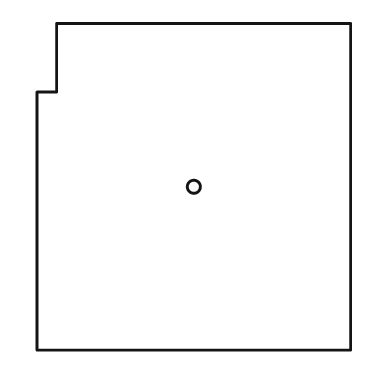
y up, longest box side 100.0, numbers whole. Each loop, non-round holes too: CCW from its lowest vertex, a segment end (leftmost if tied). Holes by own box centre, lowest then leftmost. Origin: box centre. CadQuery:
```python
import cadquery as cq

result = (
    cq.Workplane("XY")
    .moveTo(-48.0, -50.0)
    .lineTo(48.0, -50.0)
    .lineTo(48.0, 50.0)
    .lineTo(-42.0, 50.0)
    .lineTo(-42.0, 29.0)
    .lineTo(-48.0, 29.0)
    .close()
    .moveTo(0.0, 0.0)
    .circle(2.0)
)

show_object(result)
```